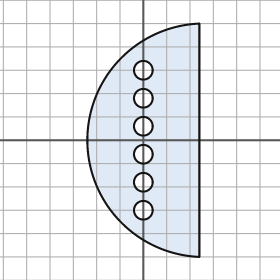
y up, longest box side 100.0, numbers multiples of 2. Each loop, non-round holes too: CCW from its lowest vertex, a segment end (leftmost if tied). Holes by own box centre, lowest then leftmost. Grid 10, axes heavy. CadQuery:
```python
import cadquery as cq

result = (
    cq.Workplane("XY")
    .moveTo(24.0, -50.0)
    .lineTo(24.0, 50.0)
    .threePointArc((-24.0, 0.0), (24.0, -50.0))
    .close()
    .moveTo(0.0, -30.0)
    .circle(4.0)
    .moveTo(0.0, -18.0)
    .circle(4.0)
    .moveTo(0.0, -6.0)
    .circle(4.0)
    .moveTo(0.0, 6.0)
    .circle(4.0)
    .moveTo(0.0, 18.0)
    .circle(4.0)
    .moveTo(0.0, 30.0)
    .circle(4.0)
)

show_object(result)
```